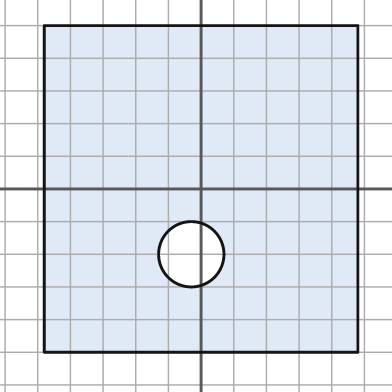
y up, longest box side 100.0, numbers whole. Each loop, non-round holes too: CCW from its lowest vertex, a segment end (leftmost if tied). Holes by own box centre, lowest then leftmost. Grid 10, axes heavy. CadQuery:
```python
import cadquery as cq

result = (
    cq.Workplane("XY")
    .moveTo(-48.0, -50.0)
    .lineTo(48.0, -50.0)
    .lineTo(48.0, 50.0)
    .lineTo(-48.0, 50.0)
    .close()
    .moveTo(-3.0, -20.0)
    .circle(10.0)
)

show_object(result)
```